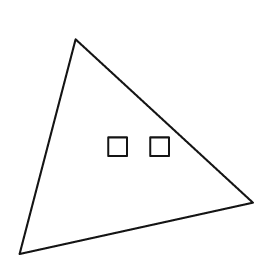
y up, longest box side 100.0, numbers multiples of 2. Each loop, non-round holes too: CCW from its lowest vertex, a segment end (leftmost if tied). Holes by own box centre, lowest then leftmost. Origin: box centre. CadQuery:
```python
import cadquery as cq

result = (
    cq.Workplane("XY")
    .moveTo(-50.0, -46.0)
    .lineTo(50.0, -24.0)
    .lineTo(-26.0, 46.0)
    .close()
    .moveTo(-12.0, -4.0)
    .lineTo(-4.0, -4.0)
    .lineTo(-4.0, 4.0)
    .lineTo(-12.0, 4.0)
    .close()
    .moveTo(6.0, -4.0)
    .lineTo(14.0, -4.0)
    .lineTo(14.0, 4.0)
    .lineTo(6.0, 4.0)
    .close()
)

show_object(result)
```